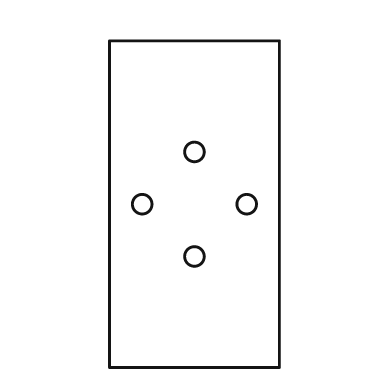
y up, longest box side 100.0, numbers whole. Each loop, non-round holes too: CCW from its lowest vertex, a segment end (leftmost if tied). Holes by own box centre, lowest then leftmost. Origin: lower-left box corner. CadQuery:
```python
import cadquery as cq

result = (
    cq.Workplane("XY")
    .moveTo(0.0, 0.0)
    .lineTo(52.0, 0.0)
    .lineTo(52.0, 100.0)
    .lineTo(0.0, 100.0)
    .close()
    .moveTo(26.0, 34.0)
    .circle(3.0)
    .moveTo(10.0, 50.0)
    .circle(3.0)
    .moveTo(42.0, 50.0)
    .circle(3.0)
    .moveTo(26.0, 66.0)
    .circle(3.0)
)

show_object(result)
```